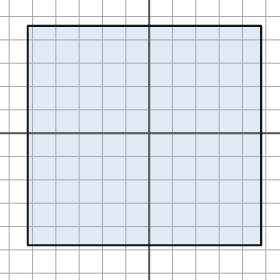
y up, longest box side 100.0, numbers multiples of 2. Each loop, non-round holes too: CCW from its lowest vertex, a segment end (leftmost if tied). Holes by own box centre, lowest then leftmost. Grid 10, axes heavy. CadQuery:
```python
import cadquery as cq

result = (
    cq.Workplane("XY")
    .moveTo(-52.0, -48.0)
    .lineTo(48.0, -48.0)
    .lineTo(48.0, 46.0)
    .lineTo(-52.0, 46.0)
    .close()
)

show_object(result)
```